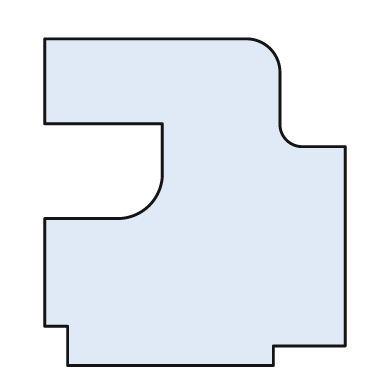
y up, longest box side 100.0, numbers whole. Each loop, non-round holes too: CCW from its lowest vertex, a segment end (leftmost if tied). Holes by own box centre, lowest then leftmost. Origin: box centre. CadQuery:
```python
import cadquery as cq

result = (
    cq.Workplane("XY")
    .moveTo(-39.0, -50.0)
    .lineTo(24.0, -50.0)
    .lineTo(24.0, -44.0)
    .lineTo(46.0, -44.0)
    .lineTo(46.0, 17.0)
    .lineTo(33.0, 17.0)
    .threePointArc((28.0, 19.0), (26.0, 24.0))
    .lineTo(26.0, 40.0)
    .threePointArc((23.0, 47.0), (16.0, 50.0))
    .lineTo(-46.0, 50.0)
    .lineTo(-46.0, 24.0)
    .lineTo(-10.0, 24.0)
    .lineTo(-10.0, 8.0)
    .threePointArc((-14.0, -1.0), (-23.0, -5.0))
    .lineTo(-46.0, -5.0)
    .lineTo(-46.0, -38.0)
    .lineTo(-39.0, -38.0)
    .close()
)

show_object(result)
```